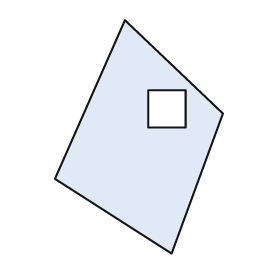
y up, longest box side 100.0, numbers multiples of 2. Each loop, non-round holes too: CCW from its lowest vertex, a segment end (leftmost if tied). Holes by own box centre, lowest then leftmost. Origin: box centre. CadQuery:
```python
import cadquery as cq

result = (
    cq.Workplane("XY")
    .moveTo(14.0, -50.0)
    .lineTo(36.0, 10.0)
    .lineTo(-6.0, 50.0)
    .lineTo(-36.0, -18.0)
    .close()
    .moveTo(4.0, 4.0)
    .lineTo(20.0, 4.0)
    .lineTo(20.0, 20.0)
    .lineTo(4.0, 20.0)
    .close()
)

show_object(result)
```